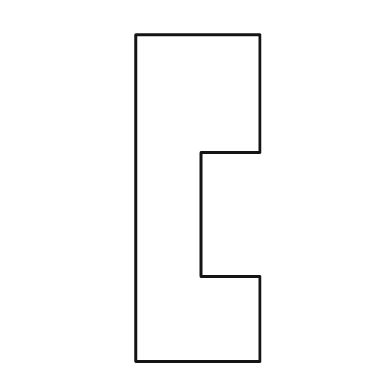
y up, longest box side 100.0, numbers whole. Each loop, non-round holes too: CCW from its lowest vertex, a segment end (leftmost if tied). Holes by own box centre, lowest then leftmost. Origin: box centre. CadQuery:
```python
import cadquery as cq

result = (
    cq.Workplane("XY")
    .moveTo(-19.0, -50.0)
    .lineTo(19.0, -50.0)
    .lineTo(19.0, -24.0)
    .lineTo(1.0, -24.0)
    .lineTo(1.0, 14.0)
    .lineTo(19.0, 14.0)
    .lineTo(19.0, 50.0)
    .lineTo(-19.0, 50.0)
    .close()
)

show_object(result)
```